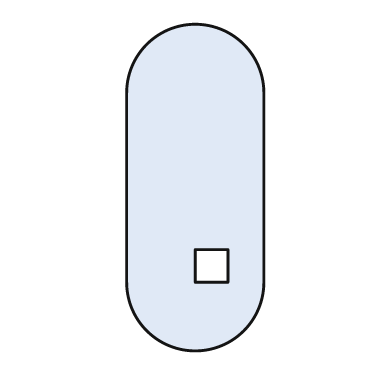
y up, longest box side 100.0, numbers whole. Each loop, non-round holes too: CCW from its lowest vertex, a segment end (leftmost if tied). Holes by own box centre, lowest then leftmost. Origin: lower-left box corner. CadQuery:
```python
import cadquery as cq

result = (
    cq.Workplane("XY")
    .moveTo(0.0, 21.0)
    .threePointArc((21.0, 0.0), (42.0, 21.0))
    .lineTo(42.0, 79.0)
    .threePointArc((21.0, 100.0), (0.0, 79.0))
    .close()
    .moveTo(21.0, 21.0)
    .lineTo(31.0, 21.0)
    .lineTo(31.0, 31.0)
    .lineTo(21.0, 31.0)
    .close()
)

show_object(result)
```